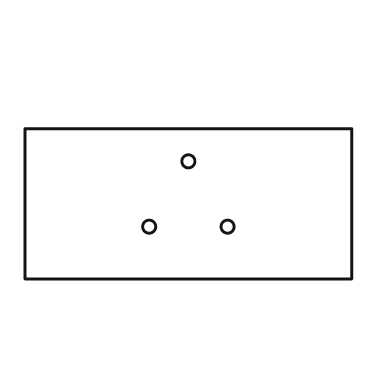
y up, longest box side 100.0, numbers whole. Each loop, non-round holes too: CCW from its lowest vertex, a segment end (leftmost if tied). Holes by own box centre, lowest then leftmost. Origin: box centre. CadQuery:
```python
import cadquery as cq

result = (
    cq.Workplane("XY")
    .moveTo(-50.0, -23.0)
    .lineTo(50.0, -23.0)
    .lineTo(50.0, 23.0)
    .lineTo(-50.0, 23.0)
    .close()
    .moveTo(-12.0, -7.0)
    .circle(2.0)
    .moveTo(12.0, -7.0)
    .circle(2.0)
    .moveTo(0.0, 13.0)
    .circle(2.0)
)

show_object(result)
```